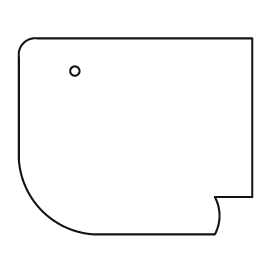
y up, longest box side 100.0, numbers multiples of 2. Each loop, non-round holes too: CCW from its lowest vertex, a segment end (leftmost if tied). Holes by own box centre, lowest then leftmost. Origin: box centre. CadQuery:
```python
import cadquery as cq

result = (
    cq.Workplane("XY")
    .moveTo(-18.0, -42.0)
    .lineTo(34.0, -42.0)
    .threePointArc((36.0, -34.0), (34.0, -26.0))
    .lineTo(50.0, -26.0)
    .lineTo(50.0, 42.0)
    .lineTo(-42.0, 42.0)
    .threePointArc((-48.0, 40.0), (-50.0, 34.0))
    .lineTo(-50.0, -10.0)
    .threePointArc((-40.0, -32.0), (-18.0, -42.0))
    .close()
    .moveTo(-26.0, 28.0)
    .circle(2.0)
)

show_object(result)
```